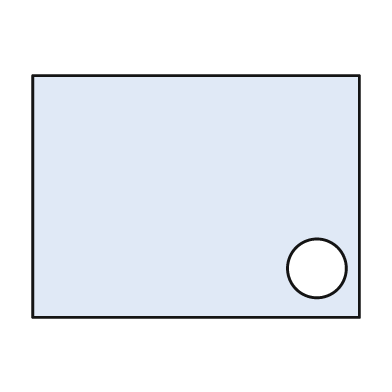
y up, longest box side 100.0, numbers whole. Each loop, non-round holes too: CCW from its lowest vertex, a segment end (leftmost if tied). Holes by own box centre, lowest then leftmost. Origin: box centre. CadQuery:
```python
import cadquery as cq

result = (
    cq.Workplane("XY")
    .moveTo(-50.0, -37.0)
    .lineTo(50.0, -37.0)
    .lineTo(50.0, 37.0)
    .lineTo(-50.0, 37.0)
    .close()
    .moveTo(37.0, -22.0)
    .circle(9.0)
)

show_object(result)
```